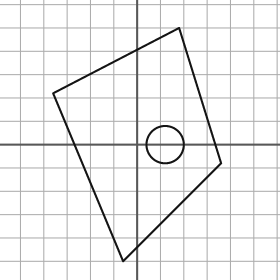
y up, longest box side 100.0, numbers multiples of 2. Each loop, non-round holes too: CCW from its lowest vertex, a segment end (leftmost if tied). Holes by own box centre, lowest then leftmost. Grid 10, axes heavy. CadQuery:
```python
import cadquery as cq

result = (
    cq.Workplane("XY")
    .moveTo(-6.0, -50.0)
    .lineTo(36.0, -8.0)
    .lineTo(18.0, 50.0)
    .lineTo(-36.0, 22.0)
    .close()
    .moveTo(12.0, 0.0)
    .circle(8.0)
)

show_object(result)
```